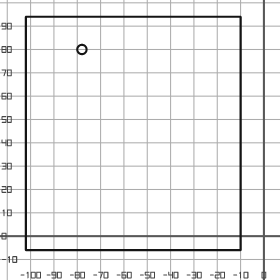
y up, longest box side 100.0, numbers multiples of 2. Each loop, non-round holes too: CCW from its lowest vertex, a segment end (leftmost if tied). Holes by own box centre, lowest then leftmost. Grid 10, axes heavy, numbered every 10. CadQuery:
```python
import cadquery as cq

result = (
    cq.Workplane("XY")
    .moveTo(-102.0, -6.0)
    .lineTo(-10.0, -6.0)
    .lineTo(-10.0, 94.0)
    .lineTo(-102.0, 94.0)
    .close()
    .moveTo(-78.0, 80.0)
    .circle(2.0)
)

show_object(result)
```